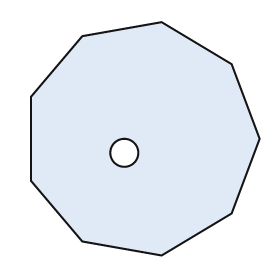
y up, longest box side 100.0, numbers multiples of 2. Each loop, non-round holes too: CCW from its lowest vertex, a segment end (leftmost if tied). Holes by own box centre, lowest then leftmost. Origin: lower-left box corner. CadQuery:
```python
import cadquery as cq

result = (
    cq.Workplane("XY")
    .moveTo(56.0, 0.0)
    .lineTo(86.0, 18.0)
    .lineTo(98.0, 50.0)
    .lineTo(86.0, 82.0)
    .lineTo(56.0, 100.0)
    .lineTo(22.0, 94.0)
    .lineTo(0.0, 68.0)
    .lineTo(0.0, 32.0)
    .lineTo(22.0, 6.0)
    .close()
    .moveTo(40.0, 44.0)
    .circle(6.0)
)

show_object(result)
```